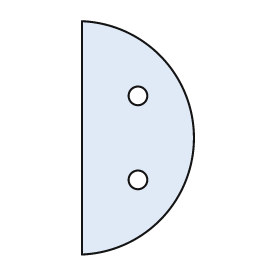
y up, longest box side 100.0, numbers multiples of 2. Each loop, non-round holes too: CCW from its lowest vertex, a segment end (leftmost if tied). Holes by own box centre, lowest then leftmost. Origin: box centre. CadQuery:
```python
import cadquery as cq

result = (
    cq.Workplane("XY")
    .moveTo(-24.0, -50.0)
    .threePointArc((24.0, 0.0), (-24.0, 50.0))
    .close()
    .moveTo(0.0, -18.0)
    .circle(4.0)
    .moveTo(0.0, 18.0)
    .circle(4.0)
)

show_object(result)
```